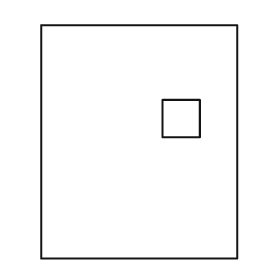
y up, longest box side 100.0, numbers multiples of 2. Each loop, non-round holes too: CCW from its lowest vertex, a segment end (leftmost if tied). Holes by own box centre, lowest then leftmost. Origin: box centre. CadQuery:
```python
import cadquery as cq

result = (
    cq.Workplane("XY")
    .moveTo(-42.0, -50.0)
    .lineTo(42.0, -50.0)
    .lineTo(42.0, 50.0)
    .lineTo(-42.0, 50.0)
    .close()
    .moveTo(10.0, 2.0)
    .lineTo(26.0, 2.0)
    .lineTo(26.0, 18.0)
    .lineTo(10.0, 18.0)
    .close()
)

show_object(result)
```